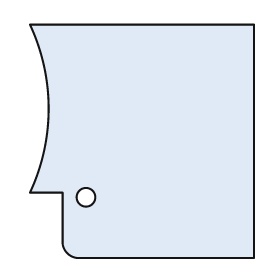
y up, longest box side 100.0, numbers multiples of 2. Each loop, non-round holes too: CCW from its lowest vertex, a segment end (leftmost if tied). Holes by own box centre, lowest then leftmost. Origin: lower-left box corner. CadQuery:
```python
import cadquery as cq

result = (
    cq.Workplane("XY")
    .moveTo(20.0, 0.0)
    .lineTo(96.0, 0.0)
    .lineTo(96.0, 100.0)
    .lineTo(0.0, 100.0)
    .threePointArc((8.0, 64.0), (0.0, 28.0))
    .lineTo(14.0, 28.0)
    .lineTo(14.0, 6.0)
    .threePointArc((16.0, 2.0), (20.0, 0.0))
    .close()
    .moveTo(24.0, 26.0)
    .circle(4.0)
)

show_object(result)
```